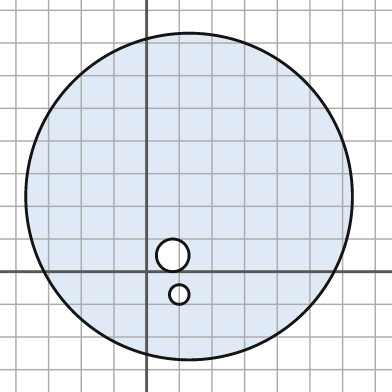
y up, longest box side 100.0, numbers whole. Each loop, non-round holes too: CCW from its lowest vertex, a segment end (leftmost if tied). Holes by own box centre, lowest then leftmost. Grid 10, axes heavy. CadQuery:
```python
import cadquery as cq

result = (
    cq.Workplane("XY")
    .moveTo(13.0, 23.0)
    .circle(50.0)
    .moveTo(10.0, -7.0)
    .circle(3.0)
    .moveTo(8.0, 5.0)
    .circle(5.0)
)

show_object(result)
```